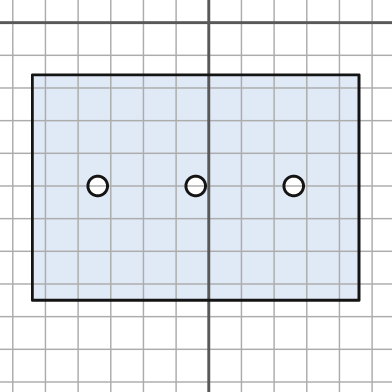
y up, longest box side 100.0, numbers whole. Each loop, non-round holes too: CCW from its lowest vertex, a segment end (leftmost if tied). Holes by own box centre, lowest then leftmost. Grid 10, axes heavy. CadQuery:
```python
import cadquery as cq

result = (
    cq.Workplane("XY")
    .moveTo(-54.0, -85.0)
    .lineTo(46.0, -85.0)
    .lineTo(46.0, -16.0)
    .lineTo(-54.0, -16.0)
    .close()
    .moveTo(-34.0, -50.0)
    .circle(3.0)
    .moveTo(-4.0, -50.0)
    .circle(3.0)
    .moveTo(26.0, -50.0)
    .circle(3.0)
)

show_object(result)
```